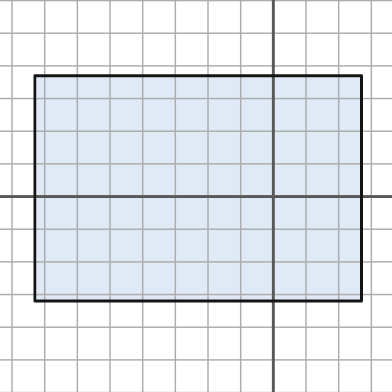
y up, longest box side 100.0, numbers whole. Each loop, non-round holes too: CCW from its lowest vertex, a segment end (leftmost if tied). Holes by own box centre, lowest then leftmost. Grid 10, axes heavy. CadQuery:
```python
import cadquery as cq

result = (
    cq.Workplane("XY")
    .moveTo(-73.0, -32.0)
    .lineTo(27.0, -32.0)
    .lineTo(27.0, 37.0)
    .lineTo(-73.0, 37.0)
    .close()
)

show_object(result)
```